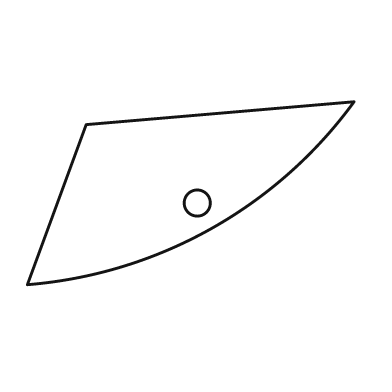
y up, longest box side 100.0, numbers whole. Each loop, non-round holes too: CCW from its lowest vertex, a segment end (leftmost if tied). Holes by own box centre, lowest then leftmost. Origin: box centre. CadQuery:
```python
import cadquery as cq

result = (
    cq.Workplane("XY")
    .moveTo(-50.0, -28.0)
    .threePointArc((6.0, -11.0), (50.0, 28.0))
    .lineTo(-32.0, 21.0)
    .close()
    .moveTo(2.0, -3.0)
    .circle(4.0)
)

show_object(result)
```